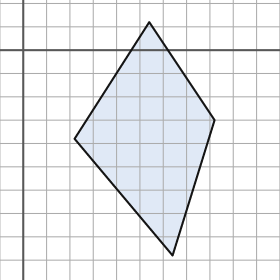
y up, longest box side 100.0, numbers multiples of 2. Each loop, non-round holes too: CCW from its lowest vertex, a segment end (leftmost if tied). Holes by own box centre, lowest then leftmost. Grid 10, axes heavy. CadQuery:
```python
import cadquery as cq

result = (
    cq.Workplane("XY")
    .moveTo(64.0, -88.0)
    .lineTo(82.0, -30.0)
    .lineTo(54.0, 12.0)
    .lineTo(22.0, -38.0)
    .close()
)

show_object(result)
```